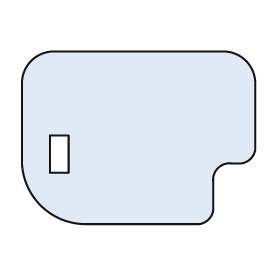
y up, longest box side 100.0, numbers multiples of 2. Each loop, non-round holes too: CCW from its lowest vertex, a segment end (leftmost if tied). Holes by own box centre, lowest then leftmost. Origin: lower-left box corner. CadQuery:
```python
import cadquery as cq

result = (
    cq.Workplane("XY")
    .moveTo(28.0, 0.0)
    .lineTo(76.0, 0.0)
    .threePointArc((80.0, 2.0), (82.0, 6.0))
    .lineTo(82.0, 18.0)
    .threePointArc((84.0, 24.0), (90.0, 26.0))
    .lineTo(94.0, 26.0)
    .threePointArc((98.0, 28.0), (100.0, 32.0))
    .lineTo(100.0, 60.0)
    .threePointArc((96.0, 70.0), (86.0, 74.0))
    .lineTo(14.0, 74.0)
    .threePointArc((4.0, 70.0), (0.0, 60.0))
    .lineTo(0.0, 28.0)
    .threePointArc((8.0, 8.0), (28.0, 0.0))
    .close()
    .moveTo(12.0, 22.0)
    .lineTo(20.0, 22.0)
    .lineTo(20.0, 38.0)
    .lineTo(12.0, 38.0)
    .close()
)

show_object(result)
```